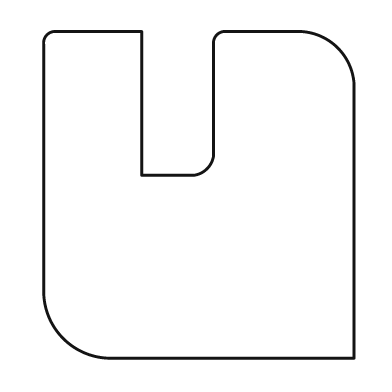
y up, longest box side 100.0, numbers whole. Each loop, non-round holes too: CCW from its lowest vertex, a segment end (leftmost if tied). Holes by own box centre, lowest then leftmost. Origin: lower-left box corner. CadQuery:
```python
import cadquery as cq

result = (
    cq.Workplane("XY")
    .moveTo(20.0, 0.0)
    .lineTo(95.0, 0.0)
    .lineTo(95.0, 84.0)
    .threePointArc((90.0, 95.0), (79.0, 100.0))
    .lineTo(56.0, 100.0)
    .threePointArc((53.0, 99.0), (52.0, 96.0))
    .lineTo(52.0, 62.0)
    .threePointArc((50.0, 58.0), (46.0, 56.0))
    .lineTo(30.0, 56.0)
    .lineTo(30.0, 100.0)
    .lineTo(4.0, 100.0)
    .threePointArc((1.0, 99.0), (0.0, 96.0))
    .lineTo(0.0, 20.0)
    .threePointArc((6.0, 6.0), (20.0, 0.0))
    .close()
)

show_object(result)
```